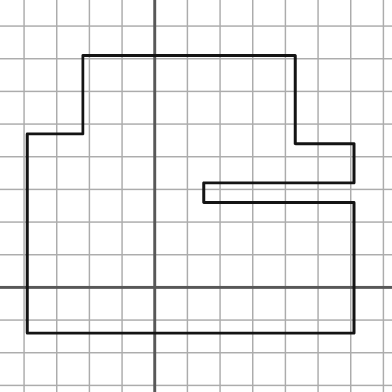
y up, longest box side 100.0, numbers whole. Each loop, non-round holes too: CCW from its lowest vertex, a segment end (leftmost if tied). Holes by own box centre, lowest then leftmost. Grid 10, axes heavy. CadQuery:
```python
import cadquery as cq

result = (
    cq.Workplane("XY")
    .moveTo(-39.0, -14.0)
    .lineTo(61.0, -14.0)
    .lineTo(61.0, 26.0)
    .lineTo(15.0, 26.0)
    .lineTo(15.0, 32.0)
    .lineTo(61.0, 32.0)
    .lineTo(61.0, 44.0)
    .lineTo(43.0, 44.0)
    .lineTo(43.0, 71.0)
    .lineTo(-22.0, 71.0)
    .lineTo(-22.0, 47.0)
    .lineTo(-39.0, 47.0)
    .close()
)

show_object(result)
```